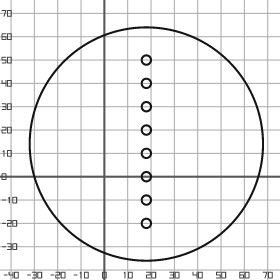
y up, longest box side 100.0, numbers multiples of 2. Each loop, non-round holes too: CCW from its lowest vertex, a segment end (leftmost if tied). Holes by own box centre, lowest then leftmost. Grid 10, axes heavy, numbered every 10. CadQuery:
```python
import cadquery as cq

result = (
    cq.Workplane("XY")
    .moveTo(18.0, 14.0)
    .circle(50.0)
    .moveTo(18.0, -20.0)
    .circle(2.0)
    .moveTo(18.0, -10.0)
    .circle(2.0)
    .moveTo(18.0, 0.0)
    .circle(2.0)
    .moveTo(18.0, 10.0)
    .circle(2.0)
    .moveTo(18.0, 20.0)
    .circle(2.0)
    .moveTo(18.0, 30.0)
    .circle(2.0)
    .moveTo(18.0, 40.0)
    .circle(2.0)
    .moveTo(18.0, 50.0)
    .circle(2.0)
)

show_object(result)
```